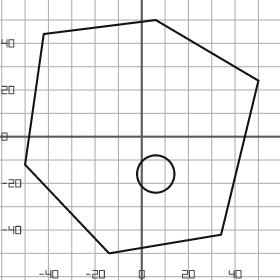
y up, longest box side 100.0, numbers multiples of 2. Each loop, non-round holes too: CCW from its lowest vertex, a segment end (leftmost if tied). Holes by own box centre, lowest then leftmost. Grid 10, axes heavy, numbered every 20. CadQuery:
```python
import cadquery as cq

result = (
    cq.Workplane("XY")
    .moveTo(-14.0, -50.0)
    .lineTo(34.0, -42.0)
    .lineTo(50.0, 24.0)
    .lineTo(6.0, 50.0)
    .lineTo(-42.0, 44.0)
    .lineTo(-50.0, -12.0)
    .close()
    .moveTo(6.0, -16.0)
    .circle(8.0)
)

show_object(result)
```